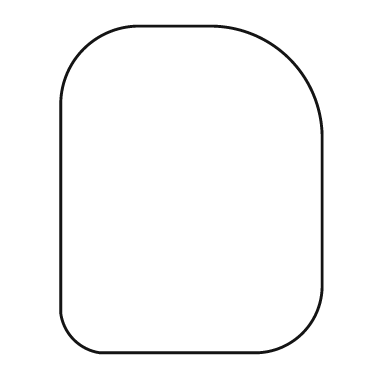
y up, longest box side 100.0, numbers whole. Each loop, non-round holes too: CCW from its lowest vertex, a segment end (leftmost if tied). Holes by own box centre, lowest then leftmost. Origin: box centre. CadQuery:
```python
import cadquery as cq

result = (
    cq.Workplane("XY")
    .moveTo(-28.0, -50.0)
    .lineTo(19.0, -50.0)
    .threePointArc((34.0, -44.0), (40.0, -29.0))
    .lineTo(40.0, 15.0)
    .threePointArc((30.0, 40.0), (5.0, 50.0))
    .lineTo(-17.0, 50.0)
    .threePointArc((-33.0, 43.0), (-40.0, 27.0))
    .lineTo(-40.0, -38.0)
    .threePointArc((-36.0, -46.0), (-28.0, -50.0))
    .close()
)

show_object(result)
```